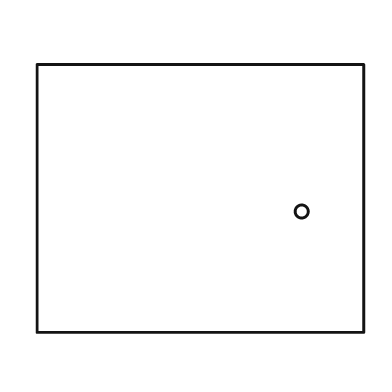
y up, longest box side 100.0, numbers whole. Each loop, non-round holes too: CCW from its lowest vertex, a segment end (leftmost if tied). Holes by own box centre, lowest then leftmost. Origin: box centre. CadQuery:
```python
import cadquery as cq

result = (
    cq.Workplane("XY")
    .moveTo(-50.0, -41.0)
    .lineTo(50.0, -41.0)
    .lineTo(50.0, 41.0)
    .lineTo(-50.0, 41.0)
    .close()
    .moveTo(31.0, -4.0)
    .circle(2.0)
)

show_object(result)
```